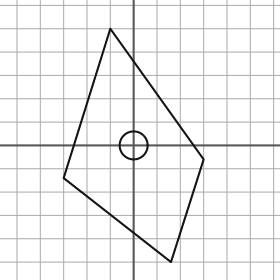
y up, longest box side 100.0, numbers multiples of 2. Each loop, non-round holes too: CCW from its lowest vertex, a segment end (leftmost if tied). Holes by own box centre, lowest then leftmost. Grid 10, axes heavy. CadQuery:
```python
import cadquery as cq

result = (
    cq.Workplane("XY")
    .moveTo(16.0, -50.0)
    .lineTo(30.0, -6.0)
    .lineTo(-10.0, 50.0)
    .lineTo(-30.0, -14.0)
    .close()
    .moveTo(0.0, 0.0)
    .circle(6.0)
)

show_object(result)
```